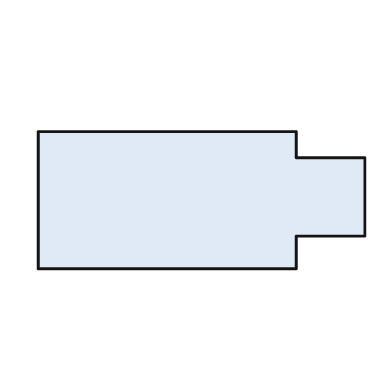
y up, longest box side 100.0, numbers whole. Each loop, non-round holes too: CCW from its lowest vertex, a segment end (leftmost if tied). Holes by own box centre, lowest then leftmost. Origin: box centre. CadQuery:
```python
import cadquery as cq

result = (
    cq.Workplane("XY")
    .moveTo(-50.0, -21.0)
    .lineTo(29.0, -21.0)
    .lineTo(29.0, -11.0)
    .lineTo(50.0, -11.0)
    .lineTo(50.0, 13.0)
    .lineTo(29.0, 13.0)
    .lineTo(29.0, 21.0)
    .lineTo(-50.0, 21.0)
    .close()
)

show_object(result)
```